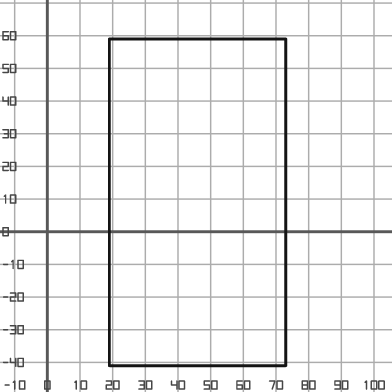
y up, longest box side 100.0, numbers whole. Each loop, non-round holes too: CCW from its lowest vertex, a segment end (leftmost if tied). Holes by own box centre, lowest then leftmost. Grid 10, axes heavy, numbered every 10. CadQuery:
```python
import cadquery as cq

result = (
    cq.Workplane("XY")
    .moveTo(19.0, -41.0)
    .lineTo(73.0, -41.0)
    .lineTo(73.0, 59.0)
    .lineTo(19.0, 59.0)
    .close()
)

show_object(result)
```